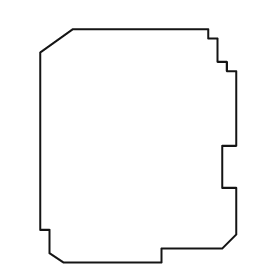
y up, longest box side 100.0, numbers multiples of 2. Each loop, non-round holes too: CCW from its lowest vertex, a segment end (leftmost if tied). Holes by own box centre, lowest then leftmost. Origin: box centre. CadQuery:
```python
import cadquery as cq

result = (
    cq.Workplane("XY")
    .moveTo(-32.0, -50.0)
    .lineTo(10.0, -50.0)
    .lineTo(10.0, -44.0)
    .lineTo(36.0, -44.0)
    .lineTo(42.0, -38.0)
    .lineTo(42.0, -18.0)
    .lineTo(36.0, -18.0)
    .lineTo(36.0, 0.0)
    .lineTo(42.0, 0.0)
    .lineTo(42.0, 32.0)
    .lineTo(38.0, 32.0)
    .lineTo(38.0, 36.0)
    .lineTo(34.0, 36.0)
    .lineTo(34.0, 46.0)
    .lineTo(30.0, 46.0)
    .lineTo(30.0, 50.0)
    .lineTo(-28.0, 50.0)
    .lineTo(-42.0, 40.0)
    .lineTo(-42.0, -36.0)
    .lineTo(-38.0, -36.0)
    .lineTo(-38.0, -46.0)
    .close()
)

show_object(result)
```